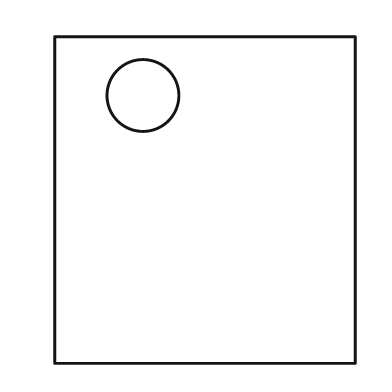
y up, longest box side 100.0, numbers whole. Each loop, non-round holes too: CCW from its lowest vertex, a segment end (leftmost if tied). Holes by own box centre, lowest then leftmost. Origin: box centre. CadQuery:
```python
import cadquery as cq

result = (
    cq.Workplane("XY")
    .moveTo(-46.0, -50.0)
    .lineTo(46.0, -50.0)
    .lineTo(46.0, 50.0)
    .lineTo(-46.0, 50.0)
    .close()
    .moveTo(-19.0, 32.0)
    .circle(11.0)
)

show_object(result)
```